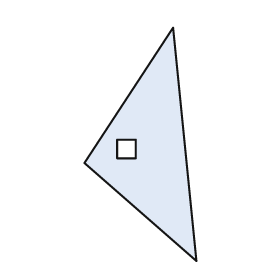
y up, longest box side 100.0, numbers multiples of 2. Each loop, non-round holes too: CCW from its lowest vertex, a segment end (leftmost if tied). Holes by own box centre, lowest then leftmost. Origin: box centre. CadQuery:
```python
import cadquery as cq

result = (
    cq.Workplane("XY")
    .moveTo(24.0, -50.0)
    .lineTo(14.0, 50.0)
    .lineTo(-24.0, -8.0)
    .close()
    .moveTo(-10.0, -6.0)
    .lineTo(-2.0, -6.0)
    .lineTo(-2.0, 2.0)
    .lineTo(-10.0, 2.0)
    .close()
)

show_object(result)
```